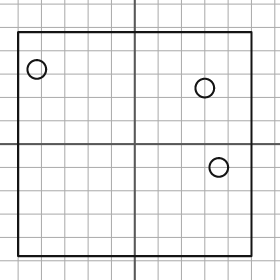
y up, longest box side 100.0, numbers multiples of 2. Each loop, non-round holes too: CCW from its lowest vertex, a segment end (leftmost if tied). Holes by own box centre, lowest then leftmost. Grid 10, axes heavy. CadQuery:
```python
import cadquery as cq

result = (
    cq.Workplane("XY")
    .moveTo(-50.0, -48.0)
    .lineTo(50.0, -48.0)
    .lineTo(50.0, 48.0)
    .lineTo(-50.0, 48.0)
    .close()
    .moveTo(36.0, -10.0)
    .circle(4.0)
    .moveTo(30.0, 24.0)
    .circle(4.0)
    .moveTo(-42.0, 32.0)
    .circle(4.0)
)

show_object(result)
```